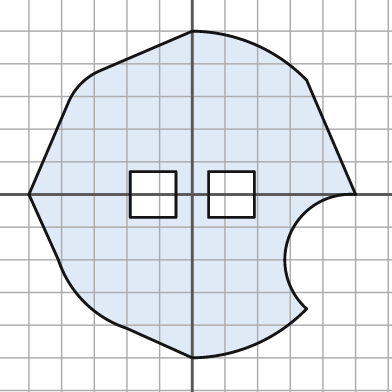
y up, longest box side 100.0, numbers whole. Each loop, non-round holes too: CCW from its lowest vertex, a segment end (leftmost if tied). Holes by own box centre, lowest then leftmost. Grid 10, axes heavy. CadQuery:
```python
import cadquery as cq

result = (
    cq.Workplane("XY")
    .moveTo(0.0, -50.0)
    .threePointArc((19.0, -46.0), (35.0, -35.0))
    .threePointArc((30.0, -12.0), (50.0, 0.0))
    .lineTo(35.0, 35.0)
    .threePointArc((19.0, 46.0), (0.0, 50.0))
    .lineTo(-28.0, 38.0)
    .threePointArc((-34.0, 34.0), (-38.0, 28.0))
    .lineTo(-50.0, 0.0)
    .lineTo(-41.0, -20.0)
    .threePointArc((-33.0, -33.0), (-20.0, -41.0))
    .close()
    .moveTo(-19.0, -7.0)
    .lineTo(-5.0, -7.0)
    .lineTo(-5.0, 7.0)
    .lineTo(-19.0, 7.0)
    .close()
    .moveTo(5.0, -7.0)
    .lineTo(19.0, -7.0)
    .lineTo(19.0, 7.0)
    .lineTo(5.0, 7.0)
    .close()
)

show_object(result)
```